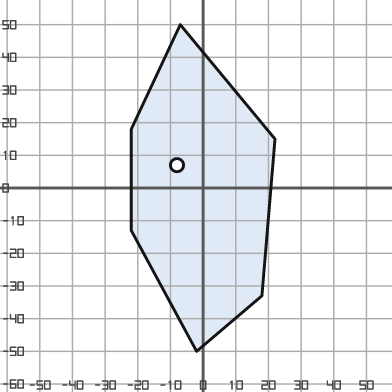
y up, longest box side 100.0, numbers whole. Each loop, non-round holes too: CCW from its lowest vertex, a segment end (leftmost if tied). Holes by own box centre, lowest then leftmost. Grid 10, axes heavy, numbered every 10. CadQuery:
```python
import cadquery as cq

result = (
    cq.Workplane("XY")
    .moveTo(-2.0, -50.0)
    .lineTo(18.0, -33.0)
    .lineTo(22.0, 15.0)
    .lineTo(-7.0, 50.0)
    .lineTo(-22.0, 18.0)
    .lineTo(-22.0, -13.0)
    .close()
    .moveTo(-8.0, 7.0)
    .circle(2.0)
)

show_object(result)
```